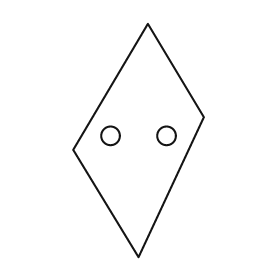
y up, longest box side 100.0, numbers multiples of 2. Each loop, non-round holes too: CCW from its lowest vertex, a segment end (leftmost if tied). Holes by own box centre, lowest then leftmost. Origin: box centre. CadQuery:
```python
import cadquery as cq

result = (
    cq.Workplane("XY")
    .moveTo(0.0, -50.0)
    .lineTo(28.0, 10.0)
    .lineTo(4.0, 50.0)
    .lineTo(-28.0, -4.0)
    .close()
    .moveTo(-12.0, 2.0)
    .circle(4.0)
    .moveTo(12.0, 2.0)
    .circle(4.0)
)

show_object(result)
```